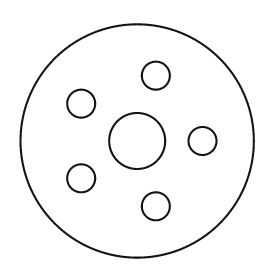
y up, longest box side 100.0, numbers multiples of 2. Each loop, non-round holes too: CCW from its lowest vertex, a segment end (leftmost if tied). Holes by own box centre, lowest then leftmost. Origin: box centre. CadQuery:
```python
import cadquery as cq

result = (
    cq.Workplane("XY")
    .moveTo(0.0, 0.0)
    .circle(50.0)
    .moveTo(8.0, -28.0)
    .circle(6.0)
    .moveTo(-24.0, -16.0)
    .circle(6.0)
    .moveTo(0.0, 0.0)
    .circle(12.0)
    .moveTo(28.0, 0.0)
    .circle(6.0)
    .moveTo(-24.0, 16.0)
    .circle(6.0)
    .moveTo(8.0, 28.0)
    .circle(6.0)
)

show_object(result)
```